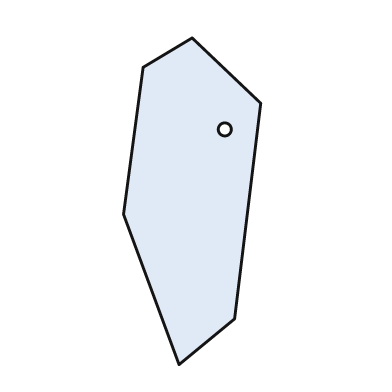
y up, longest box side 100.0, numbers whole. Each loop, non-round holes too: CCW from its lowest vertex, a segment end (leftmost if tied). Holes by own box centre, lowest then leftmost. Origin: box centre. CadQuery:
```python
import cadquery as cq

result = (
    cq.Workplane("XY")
    .moveTo(-4.0, -50.0)
    .lineTo(13.0, -36.0)
    .lineTo(21.0, 30.0)
    .lineTo(0.0, 50.0)
    .lineTo(-15.0, 41.0)
    .lineTo(-21.0, -4.0)
    .close()
    .moveTo(10.0, 22.0)
    .circle(2.0)
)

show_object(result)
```